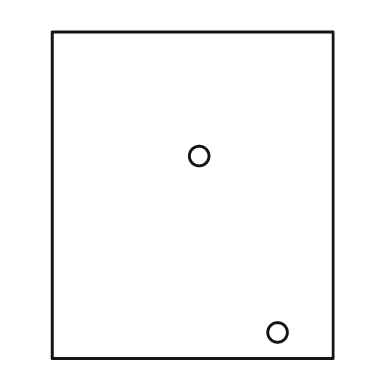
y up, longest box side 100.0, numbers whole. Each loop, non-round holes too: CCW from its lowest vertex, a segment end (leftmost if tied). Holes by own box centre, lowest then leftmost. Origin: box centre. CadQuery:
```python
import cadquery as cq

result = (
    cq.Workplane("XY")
    .moveTo(-43.0, -50.0)
    .lineTo(43.0, -50.0)
    .lineTo(43.0, 50.0)
    .lineTo(-43.0, 50.0)
    .close()
    .moveTo(26.0, -42.0)
    .circle(3.0)
    .moveTo(2.0, 12.0)
    .circle(3.0)
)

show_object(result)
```